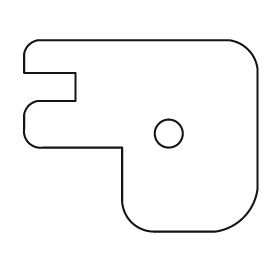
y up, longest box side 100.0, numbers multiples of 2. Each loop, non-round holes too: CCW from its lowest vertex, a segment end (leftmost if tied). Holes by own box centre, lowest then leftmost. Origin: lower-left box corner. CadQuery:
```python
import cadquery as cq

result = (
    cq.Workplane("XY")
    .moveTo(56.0, 0.0)
    .lineTo(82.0, 0.0)
    .threePointArc((94.0, 6.0), (100.0, 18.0))
    .lineTo(100.0, 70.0)
    .threePointArc((96.0, 78.0), (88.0, 82.0))
    .lineTo(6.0, 82.0)
    .threePointArc((2.0, 80.0), (0.0, 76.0))
    .lineTo(0.0, 68.0)
    .lineTo(22.0, 68.0)
    .lineTo(22.0, 56.0)
    .lineTo(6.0, 56.0)
    .threePointArc((2.0, 54.0), (0.0, 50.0))
    .lineTo(0.0, 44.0)
    .threePointArc((2.0, 38.0), (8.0, 36.0))
    .lineTo(42.0, 36.0)
    .lineTo(42.0, 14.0)
    .threePointArc((46.0, 4.0), (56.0, 0.0))
    .close()
    .moveTo(62.0, 42.0)
    .circle(6.0)
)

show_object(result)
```